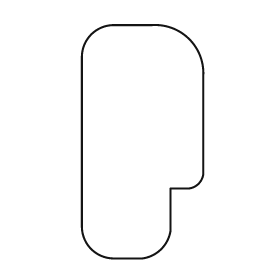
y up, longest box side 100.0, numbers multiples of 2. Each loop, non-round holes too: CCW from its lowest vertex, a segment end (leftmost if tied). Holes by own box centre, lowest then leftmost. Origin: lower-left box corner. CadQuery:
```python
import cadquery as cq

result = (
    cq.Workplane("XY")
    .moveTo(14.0, 0.0)
    .lineTo(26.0, 0.0)
    .threePointArc((34.0, 4.0), (38.0, 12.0))
    .lineTo(38.0, 30.0)
    .lineTo(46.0, 30.0)
    .threePointArc((50.0, 32.0), (52.0, 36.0))
    .lineTo(52.0, 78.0)
    .threePointArc((46.0, 94.0), (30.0, 100.0))
    .lineTo(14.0, 100.0)
    .threePointArc((4.0, 96.0), (0.0, 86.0))
    .lineTo(0.0, 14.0)
    .threePointArc((4.0, 4.0), (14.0, 0.0))
    .close()
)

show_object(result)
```